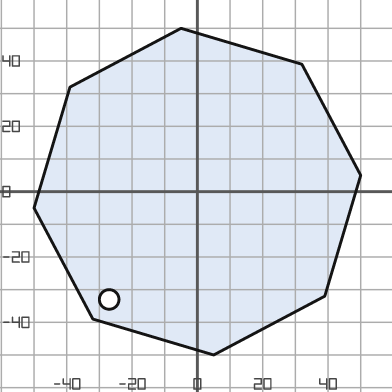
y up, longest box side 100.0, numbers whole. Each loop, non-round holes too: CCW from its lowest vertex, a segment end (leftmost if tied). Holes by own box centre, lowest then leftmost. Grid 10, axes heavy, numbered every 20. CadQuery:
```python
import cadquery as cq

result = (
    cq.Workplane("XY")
    .moveTo(5.0, -50.0)
    .lineTo(39.0, -32.0)
    .lineTo(50.0, 5.0)
    .lineTo(32.0, 39.0)
    .lineTo(-5.0, 50.0)
    .lineTo(-39.0, 32.0)
    .lineTo(-50.0, -5.0)
    .lineTo(-32.0, -39.0)
    .close()
    .moveTo(-27.0, -33.0)
    .circle(3.0)
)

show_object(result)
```